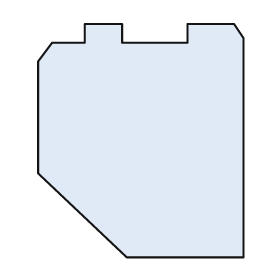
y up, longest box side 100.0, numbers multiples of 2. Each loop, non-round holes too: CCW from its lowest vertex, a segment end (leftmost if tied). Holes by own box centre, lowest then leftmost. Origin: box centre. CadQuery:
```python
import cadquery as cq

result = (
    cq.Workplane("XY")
    .moveTo(-6.0, -50.0)
    .lineTo(44.0, -50.0)
    .lineTo(44.0, 44.0)
    .lineTo(40.0, 50.0)
    .lineTo(20.0, 50.0)
    .lineTo(20.0, 42.0)
    .lineTo(-8.0, 42.0)
    .lineTo(-8.0, 50.0)
    .lineTo(-24.0, 50.0)
    .lineTo(-24.0, 42.0)
    .lineTo(-38.0, 42.0)
    .lineTo(-44.0, 34.0)
    .lineTo(-44.0, -14.0)
    .close()
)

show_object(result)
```